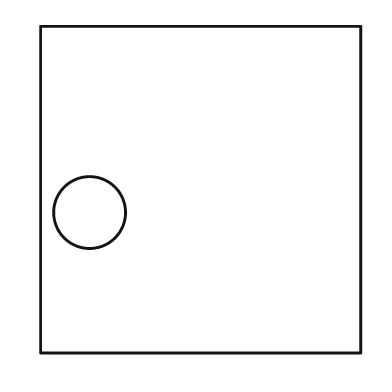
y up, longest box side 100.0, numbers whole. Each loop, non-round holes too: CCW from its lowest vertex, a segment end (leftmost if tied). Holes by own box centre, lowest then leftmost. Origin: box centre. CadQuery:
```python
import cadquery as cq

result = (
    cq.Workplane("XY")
    .moveTo(-49.0, -50.0)
    .lineTo(49.0, -50.0)
    .lineTo(49.0, 50.0)
    .lineTo(-49.0, 50.0)
    .close()
    .moveTo(-34.0, -7.0)
    .circle(11.0)
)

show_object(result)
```